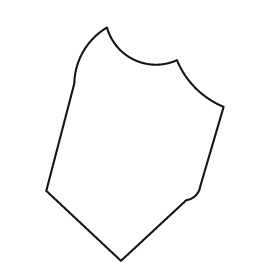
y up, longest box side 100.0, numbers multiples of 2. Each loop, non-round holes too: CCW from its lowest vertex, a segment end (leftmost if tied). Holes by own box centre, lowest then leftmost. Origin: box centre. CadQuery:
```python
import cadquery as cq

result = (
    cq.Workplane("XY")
    .moveTo(-6.0, -50.0)
    .lineTo(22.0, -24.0)
    .threePointArc((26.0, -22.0), (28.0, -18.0))
    .lineTo(38.0, 16.0)
    .threePointArc((26.0, 24.0), (18.0, 36.0))
    .threePointArc((0.0, 36.0), (-12.0, 50.0))
    .threePointArc((-22.0, 40.0), (-26.0, 26.0))
    .lineTo(-38.0, -20.0)
    .close()
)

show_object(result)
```